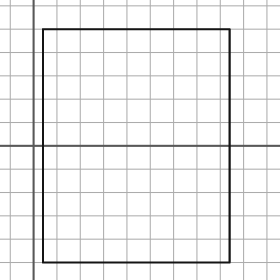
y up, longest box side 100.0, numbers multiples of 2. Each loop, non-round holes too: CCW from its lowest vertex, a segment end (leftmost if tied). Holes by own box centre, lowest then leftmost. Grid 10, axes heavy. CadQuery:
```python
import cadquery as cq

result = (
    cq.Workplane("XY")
    .moveTo(4.0, -50.0)
    .lineTo(84.0, -50.0)
    .lineTo(84.0, 50.0)
    .lineTo(4.0, 50.0)
    .close()
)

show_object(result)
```